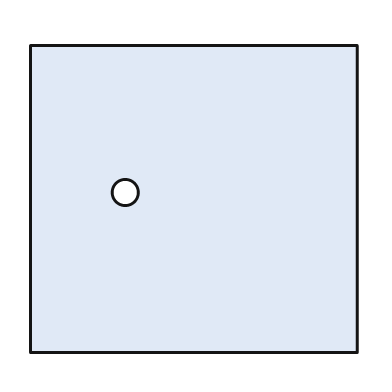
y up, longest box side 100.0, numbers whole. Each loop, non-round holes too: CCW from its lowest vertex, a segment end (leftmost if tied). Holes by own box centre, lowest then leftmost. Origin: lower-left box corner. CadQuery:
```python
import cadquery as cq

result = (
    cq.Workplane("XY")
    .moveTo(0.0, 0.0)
    .lineTo(100.0, 0.0)
    .lineTo(100.0, 94.0)
    .lineTo(0.0, 94.0)
    .close()
    .moveTo(29.0, 49.0)
    .circle(4.0)
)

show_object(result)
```